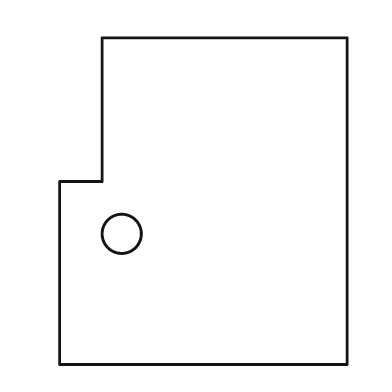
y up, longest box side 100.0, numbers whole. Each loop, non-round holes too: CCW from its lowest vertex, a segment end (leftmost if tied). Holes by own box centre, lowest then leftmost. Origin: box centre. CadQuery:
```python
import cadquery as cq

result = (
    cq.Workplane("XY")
    .moveTo(-44.0, -50.0)
    .lineTo(44.0, -50.0)
    .lineTo(44.0, 50.0)
    .lineTo(-31.0, 50.0)
    .lineTo(-31.0, 6.0)
    .lineTo(-44.0, 6.0)
    .close()
    .moveTo(-25.0, -10.0)
    .circle(6.0)
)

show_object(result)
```